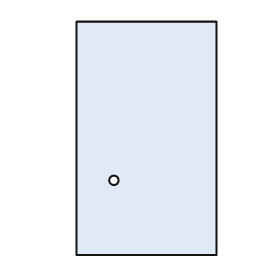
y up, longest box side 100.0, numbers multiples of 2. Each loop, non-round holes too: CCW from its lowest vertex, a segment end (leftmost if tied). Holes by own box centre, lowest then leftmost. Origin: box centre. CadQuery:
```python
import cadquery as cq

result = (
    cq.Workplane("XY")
    .moveTo(-30.0, -50.0)
    .lineTo(30.0, -50.0)
    .lineTo(30.0, 50.0)
    .lineTo(-30.0, 50.0)
    .close()
    .moveTo(-14.0, -18.0)
    .circle(2.0)
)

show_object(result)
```